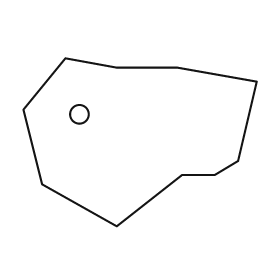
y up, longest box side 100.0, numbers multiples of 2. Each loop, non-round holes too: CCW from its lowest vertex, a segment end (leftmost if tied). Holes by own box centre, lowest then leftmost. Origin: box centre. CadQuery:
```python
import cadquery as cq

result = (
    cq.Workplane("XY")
    .moveTo(-10.0, -36.0)
    .lineTo(18.0, -14.0)
    .lineTo(32.0, -14.0)
    .lineTo(42.0, -8.0)
    .lineTo(50.0, 26.0)
    .lineTo(16.0, 32.0)
    .lineTo(-10.0, 32.0)
    .lineTo(-32.0, 36.0)
    .lineTo(-50.0, 14.0)
    .lineTo(-42.0, -18.0)
    .close()
    .moveTo(-26.0, 12.0)
    .circle(4.0)
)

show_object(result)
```